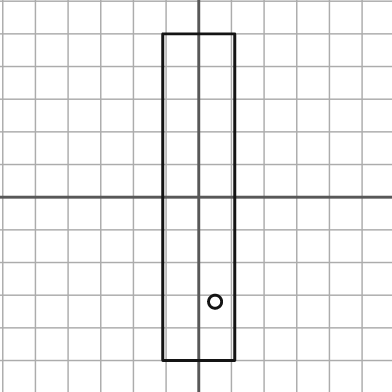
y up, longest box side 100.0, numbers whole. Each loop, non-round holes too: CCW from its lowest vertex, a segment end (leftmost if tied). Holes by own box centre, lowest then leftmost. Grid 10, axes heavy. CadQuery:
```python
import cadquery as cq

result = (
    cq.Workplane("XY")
    .moveTo(-11.0, -50.0)
    .lineTo(11.0, -50.0)
    .lineTo(11.0, 50.0)
    .lineTo(-11.0, 50.0)
    .close()
    .moveTo(5.0, -32.0)
    .circle(2.0)
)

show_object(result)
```